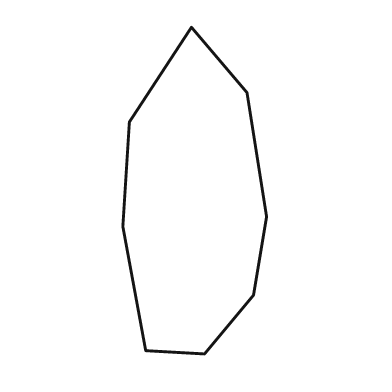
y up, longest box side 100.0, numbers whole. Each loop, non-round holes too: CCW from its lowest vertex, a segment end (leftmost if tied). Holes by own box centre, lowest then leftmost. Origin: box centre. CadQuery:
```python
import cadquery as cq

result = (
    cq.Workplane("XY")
    .moveTo(3.0, -50.0)
    .lineTo(18.0, -32.0)
    .lineTo(22.0, -8.0)
    .lineTo(16.0, 30.0)
    .lineTo(-1.0, 50.0)
    .lineTo(-20.0, 21.0)
    .lineTo(-22.0, -11.0)
    .lineTo(-15.0, -49.0)
    .close()
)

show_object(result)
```